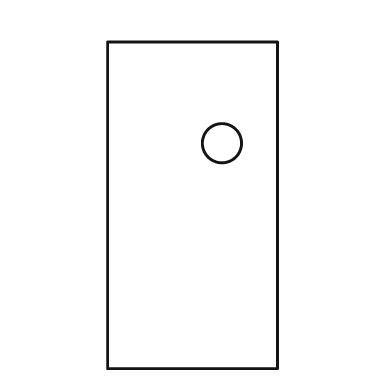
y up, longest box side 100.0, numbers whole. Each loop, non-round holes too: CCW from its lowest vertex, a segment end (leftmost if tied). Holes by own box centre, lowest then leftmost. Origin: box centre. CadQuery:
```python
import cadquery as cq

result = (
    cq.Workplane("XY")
    .moveTo(-26.0, -50.0)
    .lineTo(26.0, -50.0)
    .lineTo(26.0, 50.0)
    .lineTo(-26.0, 50.0)
    .close()
    .moveTo(9.0, 19.0)
    .circle(6.0)
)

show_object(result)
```